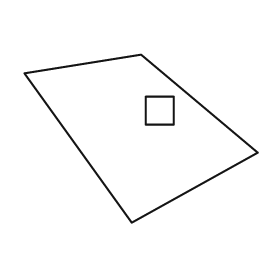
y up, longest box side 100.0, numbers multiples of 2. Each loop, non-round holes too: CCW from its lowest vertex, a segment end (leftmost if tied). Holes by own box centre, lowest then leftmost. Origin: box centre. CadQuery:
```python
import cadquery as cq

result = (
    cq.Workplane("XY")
    .moveTo(-4.0, -36.0)
    .lineTo(50.0, -6.0)
    .lineTo(0.0, 36.0)
    .lineTo(-50.0, 28.0)
    .close()
    .moveTo(2.0, 6.0)
    .lineTo(14.0, 6.0)
    .lineTo(14.0, 18.0)
    .lineTo(2.0, 18.0)
    .close()
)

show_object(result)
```